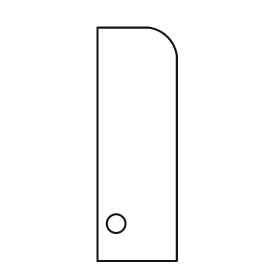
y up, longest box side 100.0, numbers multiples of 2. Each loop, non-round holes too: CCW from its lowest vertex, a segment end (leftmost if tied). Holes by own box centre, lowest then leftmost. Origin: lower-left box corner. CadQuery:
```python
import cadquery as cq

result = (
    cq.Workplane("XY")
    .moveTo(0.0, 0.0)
    .lineTo(34.0, 0.0)
    .lineTo(34.0, 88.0)
    .threePointArc((30.0, 96.0), (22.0, 100.0))
    .lineTo(0.0, 100.0)
    .close()
    .moveTo(8.0, 16.0)
    .circle(4.0)
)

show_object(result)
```